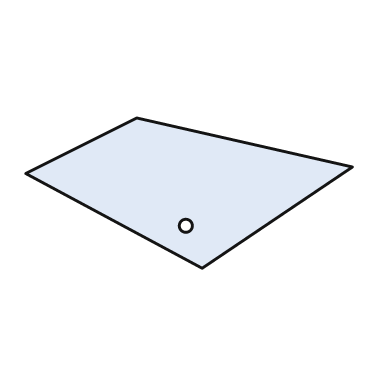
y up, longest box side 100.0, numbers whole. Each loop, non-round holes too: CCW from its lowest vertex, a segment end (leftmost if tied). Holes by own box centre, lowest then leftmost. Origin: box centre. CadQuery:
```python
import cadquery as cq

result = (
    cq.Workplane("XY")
    .moveTo(4.0, -23.0)
    .lineTo(50.0, 8.0)
    .lineTo(-16.0, 23.0)
    .lineTo(-50.0, 6.0)
    .close()
    .moveTo(-1.0, -10.0)
    .circle(2.0)
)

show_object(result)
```